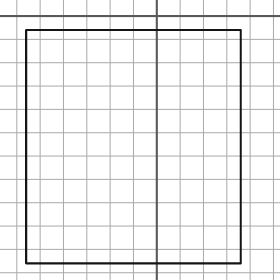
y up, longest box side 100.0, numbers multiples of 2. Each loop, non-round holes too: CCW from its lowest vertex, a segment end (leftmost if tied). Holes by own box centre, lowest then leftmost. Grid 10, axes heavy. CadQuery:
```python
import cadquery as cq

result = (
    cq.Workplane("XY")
    .moveTo(-56.0, -106.0)
    .lineTo(36.0, -106.0)
    .lineTo(36.0, -6.0)
    .lineTo(-56.0, -6.0)
    .close()
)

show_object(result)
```